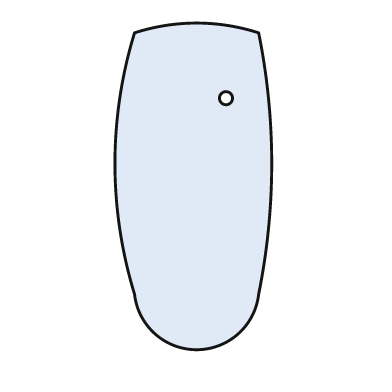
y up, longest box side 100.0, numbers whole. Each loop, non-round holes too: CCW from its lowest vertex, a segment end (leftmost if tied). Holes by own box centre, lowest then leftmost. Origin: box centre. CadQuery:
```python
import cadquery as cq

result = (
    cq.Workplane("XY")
    .moveTo(-18.0, -33.0)
    .threePointArc((1.0, -50.0), (20.0, -33.0))
    .threePointArc((24.0, 7.0), (20.0, 47.0))
    .threePointArc((1.0, 50.0), (-18.0, 47.0))
    .threePointArc((-24.0, 7.0), (-18.0, -33.0))
    .close()
    .moveTo(10.0, 27.0)
    .circle(2.0)
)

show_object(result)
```